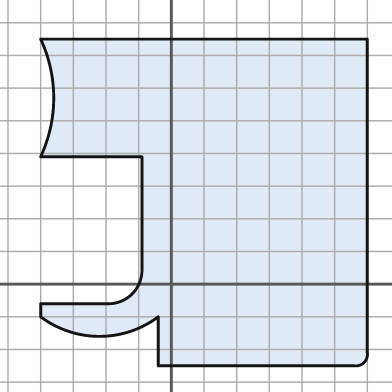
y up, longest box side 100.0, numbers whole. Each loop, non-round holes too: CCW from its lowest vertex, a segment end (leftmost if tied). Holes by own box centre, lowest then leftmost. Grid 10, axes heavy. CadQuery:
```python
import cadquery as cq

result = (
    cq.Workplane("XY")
    .moveTo(-4.0, -25.0)
    .lineTo(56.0, -25.0)
    .threePointArc((59.0, -24.0), (60.0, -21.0))
    .lineTo(60.0, 75.0)
    .lineTo(-40.0, 75.0)
    .threePointArc((-36.0, 57.0), (-40.0, 39.0))
    .lineTo(-9.0, 39.0)
    .lineTo(-9.0, 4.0)
    .threePointArc((-12.0, -3.0), (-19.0, -6.0))
    .lineTo(-40.0, -6.0)
    .lineTo(-40.0, -10.0)
    .threePointArc((-22.0, -16.0), (-4.0, -10.0))
    .close()
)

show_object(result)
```